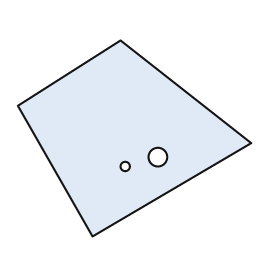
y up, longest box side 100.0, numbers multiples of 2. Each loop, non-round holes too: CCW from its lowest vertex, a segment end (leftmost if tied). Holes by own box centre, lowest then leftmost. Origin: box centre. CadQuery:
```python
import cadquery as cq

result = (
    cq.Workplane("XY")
    .moveTo(-18.0, -42.0)
    .lineTo(50.0, -2.0)
    .lineTo(-6.0, 42.0)
    .lineTo(-50.0, 14.0)
    .close()
    .moveTo(-4.0, -12.0)
    .circle(2.0)
    .moveTo(10.0, -8.0)
    .circle(4.0)
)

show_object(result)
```